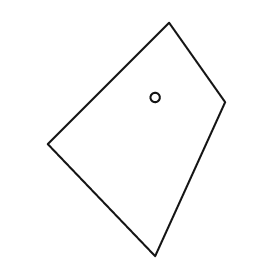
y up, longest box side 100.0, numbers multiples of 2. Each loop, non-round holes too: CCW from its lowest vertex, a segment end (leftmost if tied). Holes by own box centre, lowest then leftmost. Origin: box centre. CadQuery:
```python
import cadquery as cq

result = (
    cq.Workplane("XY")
    .moveTo(8.0, -50.0)
    .lineTo(38.0, 16.0)
    .lineTo(14.0, 50.0)
    .lineTo(-38.0, -2.0)
    .close()
    .moveTo(8.0, 18.0)
    .circle(2.0)
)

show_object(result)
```